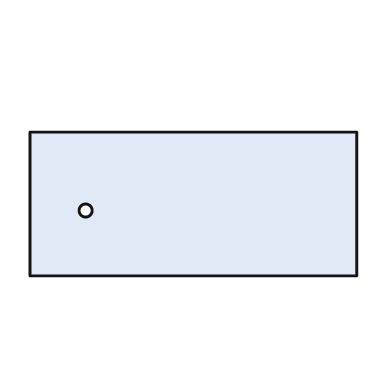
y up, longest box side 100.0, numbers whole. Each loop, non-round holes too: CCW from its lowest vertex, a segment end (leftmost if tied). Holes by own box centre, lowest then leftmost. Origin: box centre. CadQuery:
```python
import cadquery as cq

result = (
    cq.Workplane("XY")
    .moveTo(-50.0, -22.0)
    .lineTo(50.0, -22.0)
    .lineTo(50.0, 22.0)
    .lineTo(-50.0, 22.0)
    .close()
    .moveTo(-33.0, -2.0)
    .circle(2.0)
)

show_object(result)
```